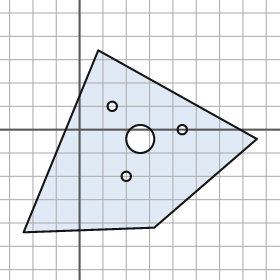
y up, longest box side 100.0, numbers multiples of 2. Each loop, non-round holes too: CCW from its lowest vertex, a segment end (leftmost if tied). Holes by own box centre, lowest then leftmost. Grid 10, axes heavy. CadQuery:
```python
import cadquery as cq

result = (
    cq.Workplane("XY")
    .moveTo(-24.0, -44.0)
    .lineTo(32.0, -42.0)
    .lineTo(76.0, -4.0)
    .lineTo(8.0, 34.0)
    .close()
    .moveTo(20.0, -20.0)
    .circle(2.0)
    .moveTo(26.0, -4.0)
    .circle(6.0)
    .moveTo(44.0, 0.0)
    .circle(2.0)
    .moveTo(14.0, 10.0)
    .circle(2.0)
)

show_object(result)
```